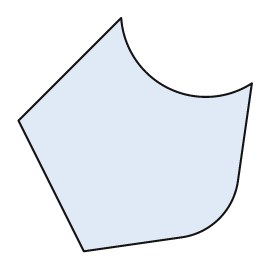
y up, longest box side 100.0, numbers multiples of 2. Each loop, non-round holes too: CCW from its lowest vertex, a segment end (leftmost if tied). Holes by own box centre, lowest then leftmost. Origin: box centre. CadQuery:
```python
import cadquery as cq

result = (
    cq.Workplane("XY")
    .moveTo(-22.0, -50.0)
    .lineTo(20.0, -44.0)
    .threePointArc((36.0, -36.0), (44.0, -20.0))
    .lineTo(50.0, 22.0)
    .threePointArc((14.0, 20.0), (-6.0, 50.0))
    .lineTo(-50.0, 6.0)
    .close()
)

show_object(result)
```